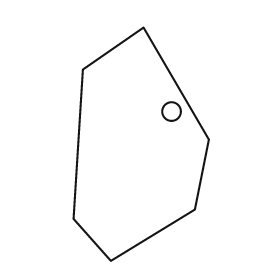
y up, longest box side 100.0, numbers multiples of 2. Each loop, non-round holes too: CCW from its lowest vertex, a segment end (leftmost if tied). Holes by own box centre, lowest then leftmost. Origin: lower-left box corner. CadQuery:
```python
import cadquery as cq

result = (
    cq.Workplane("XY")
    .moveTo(16.0, 0.0)
    .lineTo(52.0, 22.0)
    .lineTo(58.0, 52.0)
    .lineTo(30.0, 100.0)
    .lineTo(4.0, 82.0)
    .lineTo(0.0, 18.0)
    .close()
    .moveTo(42.0, 64.0)
    .circle(4.0)
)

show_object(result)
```